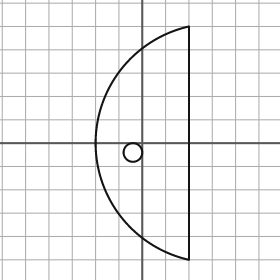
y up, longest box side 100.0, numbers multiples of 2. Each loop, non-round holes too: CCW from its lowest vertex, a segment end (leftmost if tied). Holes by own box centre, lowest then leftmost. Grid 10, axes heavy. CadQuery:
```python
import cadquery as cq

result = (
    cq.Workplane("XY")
    .moveTo(20.0, -50.0)
    .lineTo(20.0, 50.0)
    .threePointArc((-20.0, 0.0), (20.0, -50.0))
    .close()
    .moveTo(-4.0, -4.0)
    .circle(4.0)
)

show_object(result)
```